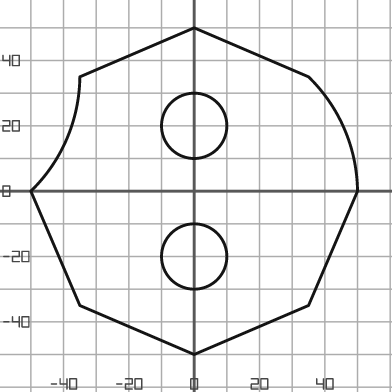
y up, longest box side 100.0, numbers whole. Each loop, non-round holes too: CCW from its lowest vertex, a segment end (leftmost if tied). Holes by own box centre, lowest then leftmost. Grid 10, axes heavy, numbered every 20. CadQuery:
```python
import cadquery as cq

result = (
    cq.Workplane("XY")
    .moveTo(0.0, -50.0)
    .lineTo(35.0, -35.0)
    .lineTo(50.0, 0.0)
    .threePointArc((46.0, 19.0), (35.0, 35.0))
    .lineTo(0.0, 50.0)
    .lineTo(-35.0, 35.0)
    .threePointArc((-39.0, 16.0), (-50.0, 0.0))
    .lineTo(-35.0, -35.0)
    .close()
    .moveTo(0.0, -20.0)
    .circle(10.0)
    .moveTo(0.0, 20.0)
    .circle(10.0)
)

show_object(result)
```